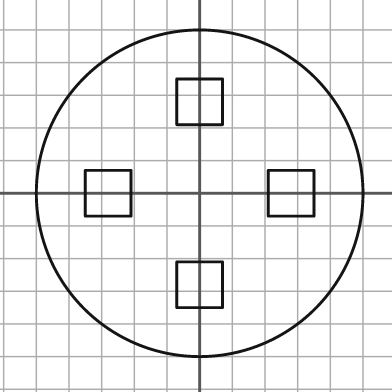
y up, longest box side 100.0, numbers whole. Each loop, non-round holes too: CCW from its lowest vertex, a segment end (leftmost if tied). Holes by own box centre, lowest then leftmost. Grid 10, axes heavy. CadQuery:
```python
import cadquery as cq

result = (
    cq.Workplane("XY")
    .moveTo(0.0, 0.0)
    .circle(50.0)
    .moveTo(-7.0, -35.0)
    .lineTo(7.0, -35.0)
    .lineTo(7.0, -21.0)
    .lineTo(-7.0, -21.0)
    .close()
    .moveTo(-35.0, -7.0)
    .lineTo(-21.0, -7.0)
    .lineTo(-21.0, 7.0)
    .lineTo(-35.0, 7.0)
    .close()
    .moveTo(21.0, -7.0)
    .lineTo(35.0, -7.0)
    .lineTo(35.0, 7.0)
    .lineTo(21.0, 7.0)
    .close()
    .moveTo(-7.0, 21.0)
    .lineTo(7.0, 21.0)
    .lineTo(7.0, 35.0)
    .lineTo(-7.0, 35.0)
    .close()
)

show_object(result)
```